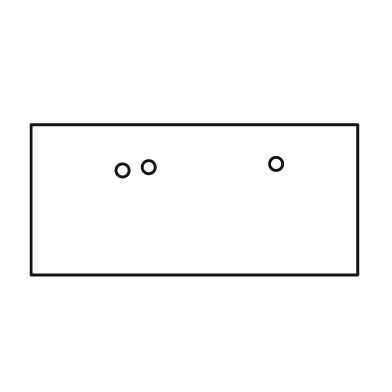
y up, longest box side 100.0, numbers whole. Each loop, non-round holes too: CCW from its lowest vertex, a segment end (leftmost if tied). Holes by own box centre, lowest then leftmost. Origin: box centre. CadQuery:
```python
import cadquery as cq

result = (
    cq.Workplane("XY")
    .moveTo(-50.0, -23.0)
    .lineTo(50.0, -23.0)
    .lineTo(50.0, 23.0)
    .lineTo(-50.0, 23.0)
    .close()
    .moveTo(-22.0, 9.0)
    .circle(2.0)
    .moveTo(-14.0, 10.0)
    .circle(2.0)
    .moveTo(25.0, 11.0)
    .circle(2.0)
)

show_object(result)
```